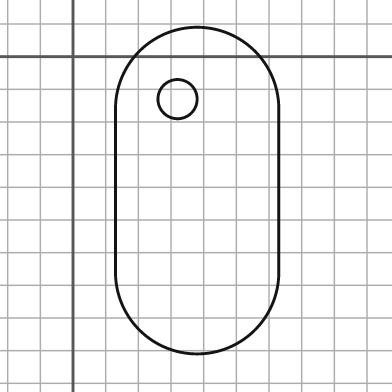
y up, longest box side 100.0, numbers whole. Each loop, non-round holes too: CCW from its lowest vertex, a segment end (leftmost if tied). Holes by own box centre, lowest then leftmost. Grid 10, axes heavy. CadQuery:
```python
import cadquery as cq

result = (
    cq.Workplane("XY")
    .moveTo(13.0, -66.0)
    .threePointArc((38.0, -91.0), (63.0, -66.0))
    .lineTo(63.0, -16.0)
    .threePointArc((38.0, 9.0), (13.0, -16.0))
    .close()
    .moveTo(32.0, -13.0)
    .circle(6.0)
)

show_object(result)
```